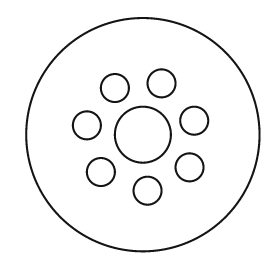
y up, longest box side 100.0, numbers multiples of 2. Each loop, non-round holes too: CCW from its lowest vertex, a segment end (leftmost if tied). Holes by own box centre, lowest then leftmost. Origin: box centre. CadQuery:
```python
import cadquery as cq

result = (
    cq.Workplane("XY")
    .moveTo(0.0, 0.0)
    .circle(50.0)
    .moveTo(2.0, -24.0)
    .circle(6.0)
    .moveTo(-18.0, -16.0)
    .circle(6.0)
    .moveTo(20.0, -14.0)
    .circle(6.0)
    .moveTo(0.0, 0.0)
    .circle(12.0)
    .moveTo(-24.0, 4.0)
    .circle(6.0)
    .moveTo(22.0, 6.0)
    .circle(6.0)
    .moveTo(-12.0, 20.0)
    .circle(6.0)
    .moveTo(8.0, 22.0)
    .circle(6.0)
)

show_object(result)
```